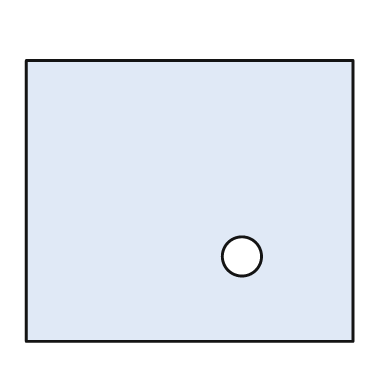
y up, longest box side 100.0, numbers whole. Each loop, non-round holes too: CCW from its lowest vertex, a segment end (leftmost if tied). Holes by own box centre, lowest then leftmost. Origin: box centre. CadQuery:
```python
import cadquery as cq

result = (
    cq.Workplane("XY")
    .moveTo(-50.0, -43.0)
    .lineTo(50.0, -43.0)
    .lineTo(50.0, 43.0)
    .lineTo(-50.0, 43.0)
    .close()
    .moveTo(16.0, -17.0)
    .circle(6.0)
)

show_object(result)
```